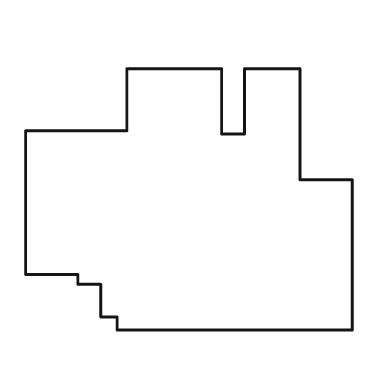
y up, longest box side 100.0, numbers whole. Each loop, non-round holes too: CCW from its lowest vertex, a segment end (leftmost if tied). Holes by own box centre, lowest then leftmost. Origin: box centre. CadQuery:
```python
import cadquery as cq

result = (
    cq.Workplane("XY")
    .moveTo(-22.0, -40.0)
    .lineTo(50.0, -40.0)
    .lineTo(50.0, 6.0)
    .lineTo(34.0, 6.0)
    .lineTo(34.0, 40.0)
    .lineTo(17.0, 40.0)
    .lineTo(17.0, 20.0)
    .lineTo(10.0, 20.0)
    .lineTo(10.0, 40.0)
    .lineTo(-19.0, 40.0)
    .lineTo(-19.0, 21.0)
    .lineTo(-50.0, 21.0)
    .lineTo(-50.0, -23.0)
    .lineTo(-34.0, -23.0)
    .lineTo(-34.0, -26.0)
    .lineTo(-27.0, -26.0)
    .lineTo(-27.0, -36.0)
    .lineTo(-22.0, -36.0)
    .close()
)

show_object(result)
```